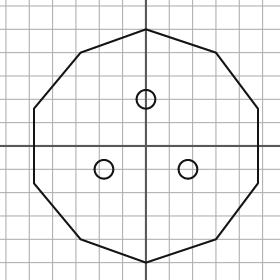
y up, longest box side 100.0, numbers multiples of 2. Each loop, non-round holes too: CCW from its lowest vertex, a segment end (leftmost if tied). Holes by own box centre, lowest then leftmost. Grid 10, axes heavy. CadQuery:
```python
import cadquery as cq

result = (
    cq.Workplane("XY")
    .moveTo(0.0, -50.0)
    .lineTo(30.0, -40.0)
    .lineTo(48.0, -16.0)
    .lineTo(48.0, 16.0)
    .lineTo(30.0, 40.0)
    .lineTo(0.0, 50.0)
    .lineTo(-28.0, 40.0)
    .lineTo(-48.0, 16.0)
    .lineTo(-48.0, -16.0)
    .lineTo(-28.0, -40.0)
    .close()
    .moveTo(-18.0, -10.0)
    .circle(4.0)
    .moveTo(18.0, -10.0)
    .circle(4.0)
    .moveTo(0.0, 20.0)
    .circle(4.0)
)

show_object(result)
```